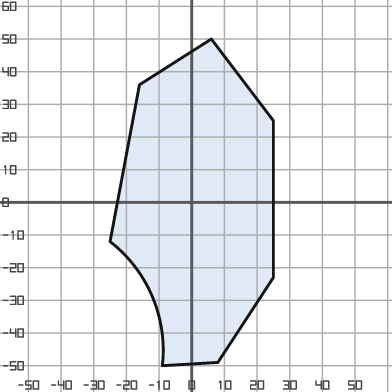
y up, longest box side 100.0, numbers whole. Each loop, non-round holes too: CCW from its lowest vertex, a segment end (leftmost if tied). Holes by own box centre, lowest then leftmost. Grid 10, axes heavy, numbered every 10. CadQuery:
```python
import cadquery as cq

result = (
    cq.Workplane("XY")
    .moveTo(-9.0, -50.0)
    .lineTo(8.0, -49.0)
    .lineTo(25.0, -23.0)
    .lineTo(25.0, 25.0)
    .lineTo(6.0, 50.0)
    .lineTo(-16.0, 36.0)
    .lineTo(-25.0, -12.0)
    .threePointArc((-12.0, -29.0), (-9.0, -50.0))
    .close()
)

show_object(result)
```